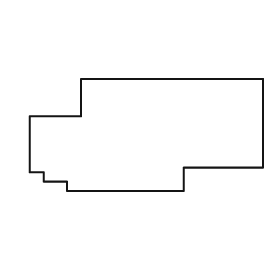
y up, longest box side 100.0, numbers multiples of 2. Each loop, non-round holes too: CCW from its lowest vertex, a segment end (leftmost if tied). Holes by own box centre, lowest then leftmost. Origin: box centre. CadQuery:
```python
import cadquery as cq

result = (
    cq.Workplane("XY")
    .moveTo(-34.0, -24.0)
    .lineTo(16.0, -24.0)
    .lineTo(16.0, -14.0)
    .lineTo(50.0, -14.0)
    .lineTo(50.0, 24.0)
    .lineTo(-28.0, 24.0)
    .lineTo(-28.0, 8.0)
    .lineTo(-50.0, 8.0)
    .lineTo(-50.0, -16.0)
    .lineTo(-44.0, -16.0)
    .lineTo(-44.0, -20.0)
    .lineTo(-34.0, -20.0)
    .close()
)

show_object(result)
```